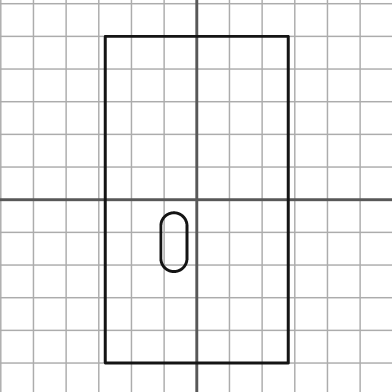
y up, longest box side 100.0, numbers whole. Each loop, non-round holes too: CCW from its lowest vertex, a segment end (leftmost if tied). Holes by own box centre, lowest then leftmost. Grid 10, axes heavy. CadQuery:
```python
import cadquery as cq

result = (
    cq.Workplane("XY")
    .moveTo(-28.0, -50.0)
    .lineTo(28.0, -50.0)
    .lineTo(28.0, 50.0)
    .lineTo(-28.0, 50.0)
    .close()
    .moveTo(-11.0, -18.0)
    .threePointArc((-7.0, -22.0), (-3.0, -18.0))
    .lineTo(-3.0, -8.0)
    .threePointArc((-7.0, -4.0), (-11.0, -8.0))
    .close()
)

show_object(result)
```